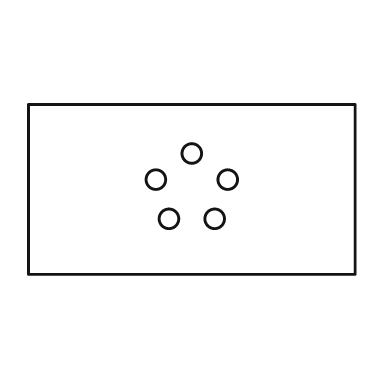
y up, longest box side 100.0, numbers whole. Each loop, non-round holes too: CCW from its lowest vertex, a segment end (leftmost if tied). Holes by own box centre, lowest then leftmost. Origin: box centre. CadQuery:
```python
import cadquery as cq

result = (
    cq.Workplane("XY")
    .moveTo(-50.0, -26.0)
    .lineTo(50.0, -26.0)
    .lineTo(50.0, 26.0)
    .lineTo(-50.0, 26.0)
    .close()
    .moveTo(-7.0, -9.0)
    .circle(3.0)
    .moveTo(7.0, -9.0)
    .circle(3.0)
    .moveTo(-11.0, 3.0)
    .circle(3.0)
    .moveTo(11.0, 3.0)
    .circle(3.0)
    .moveTo(0.0, 11.0)
    .circle(3.0)
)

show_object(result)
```